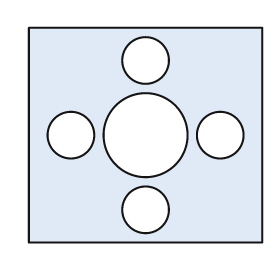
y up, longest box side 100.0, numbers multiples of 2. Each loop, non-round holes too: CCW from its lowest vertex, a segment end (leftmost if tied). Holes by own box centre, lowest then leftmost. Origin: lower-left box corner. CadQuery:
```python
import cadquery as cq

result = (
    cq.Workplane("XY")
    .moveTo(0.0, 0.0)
    .lineTo(100.0, 0.0)
    .lineTo(100.0, 92.0)
    .lineTo(0.0, 92.0)
    .close()
    .moveTo(50.0, 14.0)
    .circle(10.0)
    .moveTo(18.0, 46.0)
    .circle(10.0)
    .moveTo(50.0, 46.0)
    .circle(18.0)
    .moveTo(82.0, 46.0)
    .circle(10.0)
    .moveTo(50.0, 78.0)
    .circle(10.0)
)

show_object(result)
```